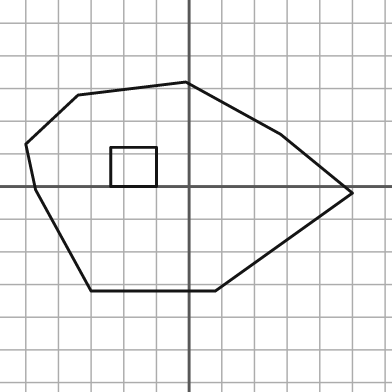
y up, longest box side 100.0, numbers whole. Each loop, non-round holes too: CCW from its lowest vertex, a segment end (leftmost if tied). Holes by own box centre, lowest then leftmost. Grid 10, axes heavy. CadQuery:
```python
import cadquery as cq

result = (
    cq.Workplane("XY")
    .moveTo(-30.0, -32.0)
    .lineTo(8.0, -32.0)
    .lineTo(50.0, -2.0)
    .lineTo(28.0, 16.0)
    .lineTo(-1.0, 32.0)
    .lineTo(-34.0, 28.0)
    .lineTo(-50.0, 13.0)
    .lineTo(-47.0, -1.0)
    .close()
    .moveTo(-24.0, 0.0)
    .lineTo(-10.0, 0.0)
    .lineTo(-10.0, 12.0)
    .lineTo(-24.0, 12.0)
    .close()
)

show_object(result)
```